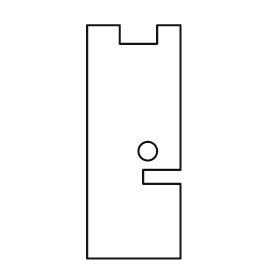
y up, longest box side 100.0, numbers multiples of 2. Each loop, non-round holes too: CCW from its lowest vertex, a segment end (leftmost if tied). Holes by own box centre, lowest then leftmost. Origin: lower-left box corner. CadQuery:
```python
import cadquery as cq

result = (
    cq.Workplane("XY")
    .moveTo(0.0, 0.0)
    .lineTo(40.0, 0.0)
    .lineTo(40.0, 32.0)
    .lineTo(24.0, 32.0)
    .lineTo(24.0, 38.0)
    .lineTo(40.0, 38.0)
    .lineTo(40.0, 100.0)
    .lineTo(30.0, 100.0)
    .lineTo(30.0, 92.0)
    .lineTo(14.0, 92.0)
    .lineTo(14.0, 100.0)
    .lineTo(0.0, 100.0)
    .close()
    .moveTo(26.0, 46.0)
    .circle(4.0)
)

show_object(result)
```